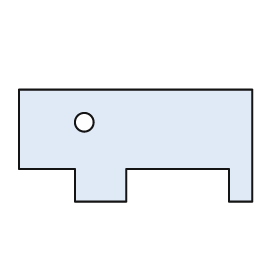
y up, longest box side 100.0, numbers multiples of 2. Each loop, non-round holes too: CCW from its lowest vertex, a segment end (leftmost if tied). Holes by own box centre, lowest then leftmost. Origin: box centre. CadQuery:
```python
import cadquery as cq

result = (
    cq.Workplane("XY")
    .moveTo(-26.0, -24.0)
    .lineTo(-4.0, -24.0)
    .lineTo(-4.0, -10.0)
    .lineTo(40.0, -10.0)
    .lineTo(40.0, -24.0)
    .lineTo(50.0, -24.0)
    .lineTo(50.0, 24.0)
    .lineTo(-50.0, 24.0)
    .lineTo(-50.0, -10.0)
    .lineTo(-26.0, -10.0)
    .close()
    .moveTo(-22.0, 10.0)
    .circle(4.0)
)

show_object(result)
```